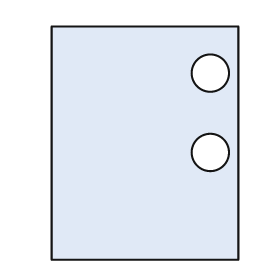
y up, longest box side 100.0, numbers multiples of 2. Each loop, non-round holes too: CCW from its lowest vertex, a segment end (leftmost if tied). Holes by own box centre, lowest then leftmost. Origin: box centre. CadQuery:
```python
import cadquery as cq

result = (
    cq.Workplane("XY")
    .moveTo(-40.0, -50.0)
    .lineTo(40.0, -50.0)
    .lineTo(40.0, 50.0)
    .lineTo(-40.0, 50.0)
    .close()
    .moveTo(28.0, -4.0)
    .circle(8.0)
    .moveTo(28.0, 30.0)
    .circle(8.0)
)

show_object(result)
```